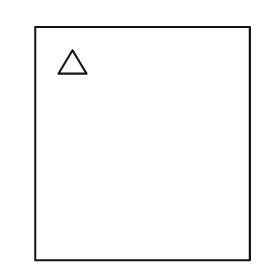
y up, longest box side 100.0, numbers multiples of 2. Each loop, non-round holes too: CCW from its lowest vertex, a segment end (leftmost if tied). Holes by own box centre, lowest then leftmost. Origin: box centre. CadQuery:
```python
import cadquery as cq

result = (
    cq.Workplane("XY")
    .moveTo(-46.0, -50.0)
    .lineTo(46.0, -50.0)
    .lineTo(46.0, 50.0)
    .lineTo(-46.0, 50.0)
    .close()
    .moveTo(-36.0, 30.0)
    .lineTo(-24.0, 30.0)
    .lineTo(-30.0, 40.0)
    .close()
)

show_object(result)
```